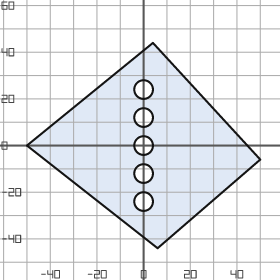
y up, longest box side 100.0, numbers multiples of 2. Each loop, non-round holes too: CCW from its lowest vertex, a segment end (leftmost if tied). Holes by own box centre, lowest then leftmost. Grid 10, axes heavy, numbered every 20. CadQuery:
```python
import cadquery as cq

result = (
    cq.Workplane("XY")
    .moveTo(6.0, -44.0)
    .lineTo(50.0, -6.0)
    .lineTo(4.0, 44.0)
    .lineTo(-50.0, 0.0)
    .close()
    .moveTo(0.0, -24.0)
    .circle(4.0)
    .moveTo(0.0, -12.0)
    .circle(4.0)
    .moveTo(0.0, 0.0)
    .circle(4.0)
    .moveTo(0.0, 12.0)
    .circle(4.0)
    .moveTo(0.0, 24.0)
    .circle(4.0)
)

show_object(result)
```